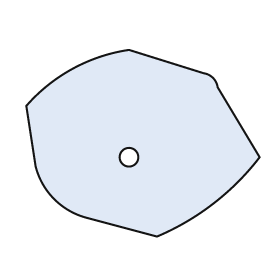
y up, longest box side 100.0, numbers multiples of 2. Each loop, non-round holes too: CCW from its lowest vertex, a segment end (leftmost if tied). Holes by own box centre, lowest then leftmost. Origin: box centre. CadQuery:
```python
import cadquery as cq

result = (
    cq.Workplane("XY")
    .moveTo(6.0, -40.0)
    .threePointArc((30.0, -26.0), (50.0, -6.0))
    .lineTo(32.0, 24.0)
    .threePointArc((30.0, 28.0), (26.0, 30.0))
    .lineTo(-6.0, 40.0)
    .threePointArc((-30.0, 32.0), (-50.0, 16.0))
    .lineTo(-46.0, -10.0)
    .threePointArc((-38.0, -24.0), (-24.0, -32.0))
    .close()
    .moveTo(-6.0, -6.0)
    .circle(4.0)
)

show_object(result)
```